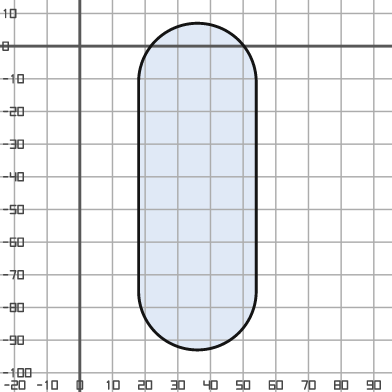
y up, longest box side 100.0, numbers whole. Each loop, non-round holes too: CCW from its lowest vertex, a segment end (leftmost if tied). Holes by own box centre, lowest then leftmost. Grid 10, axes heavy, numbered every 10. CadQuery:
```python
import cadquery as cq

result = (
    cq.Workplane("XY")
    .moveTo(18.0, -75.0)
    .threePointArc((36.0, -93.0), (54.0, -75.0))
    .lineTo(54.0, -11.0)
    .threePointArc((36.0, 7.0), (18.0, -11.0))
    .close()
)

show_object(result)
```